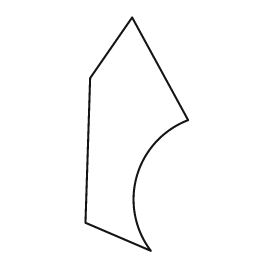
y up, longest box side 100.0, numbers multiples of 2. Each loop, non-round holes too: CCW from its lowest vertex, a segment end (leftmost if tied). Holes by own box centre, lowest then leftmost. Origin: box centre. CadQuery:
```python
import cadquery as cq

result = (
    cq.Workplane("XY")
    .moveTo(6.0, -50.0)
    .threePointArc((0.0, -18.0), (22.0, 6.0))
    .lineTo(-2.0, 50.0)
    .lineTo(-20.0, 24.0)
    .lineTo(-22.0, -38.0)
    .close()
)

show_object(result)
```